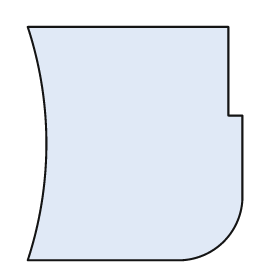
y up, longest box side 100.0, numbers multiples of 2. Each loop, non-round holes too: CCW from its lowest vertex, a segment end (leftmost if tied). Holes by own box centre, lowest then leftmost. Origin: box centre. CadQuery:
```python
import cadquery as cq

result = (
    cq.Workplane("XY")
    .moveTo(-46.0, -50.0)
    .lineTo(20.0, -50.0)
    .threePointArc((38.0, -42.0), (46.0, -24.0))
    .lineTo(46.0, 12.0)
    .lineTo(40.0, 12.0)
    .lineTo(40.0, 50.0)
    .lineTo(-46.0, 50.0)
    .threePointArc((-38.0, 0.0), (-46.0, -50.0))
    .close()
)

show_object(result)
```